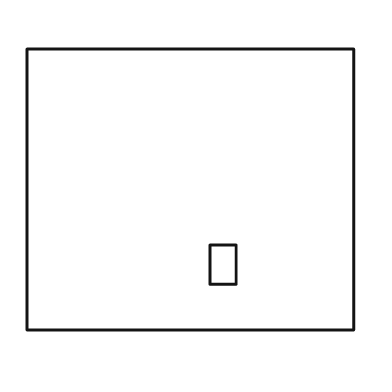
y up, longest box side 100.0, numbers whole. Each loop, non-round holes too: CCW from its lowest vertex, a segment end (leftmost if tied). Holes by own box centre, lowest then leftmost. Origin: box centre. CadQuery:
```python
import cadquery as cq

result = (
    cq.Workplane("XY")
    .moveTo(-50.0, -43.0)
    .lineTo(50.0, -43.0)
    .lineTo(50.0, 43.0)
    .lineTo(-50.0, 43.0)
    .close()
    .moveTo(6.0, -29.0)
    .lineTo(14.0, -29.0)
    .lineTo(14.0, -17.0)
    .lineTo(6.0, -17.0)
    .close()
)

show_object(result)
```